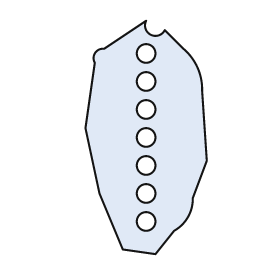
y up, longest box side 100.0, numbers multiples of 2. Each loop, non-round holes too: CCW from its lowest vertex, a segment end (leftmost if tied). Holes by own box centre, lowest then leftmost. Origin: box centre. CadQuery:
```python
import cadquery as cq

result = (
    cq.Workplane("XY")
    .moveTo(4.0, -50.0)
    .lineTo(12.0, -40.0)
    .threePointArc((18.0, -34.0), (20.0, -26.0))
    .lineTo(26.0, -10.0)
    .lineTo(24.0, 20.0)
    .threePointArc((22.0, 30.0), (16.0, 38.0))
    .lineTo(8.0, 46.0)
    .threePointArc((2.0, 44.0), (0.0, 50.0))
    .lineTo(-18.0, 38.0)
    .threePointArc((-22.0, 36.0), (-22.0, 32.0))
    .lineTo(-26.0, 4.0)
    .lineTo(-20.0, -24.0)
    .lineTo(-10.0, -48.0)
    .close()
    .moveTo(0.0, -36.0)
    .circle(4.0)
    .moveTo(0.0, -24.0)
    .circle(4.0)
    .moveTo(0.0, -12.0)
    .circle(4.0)
    .moveTo(0.0, 0.0)
    .circle(4.0)
    .moveTo(0.0, 12.0)
    .circle(4.0)
    .moveTo(0.0, 24.0)
    .circle(4.0)
    .moveTo(0.0, 36.0)
    .circle(4.0)
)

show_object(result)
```